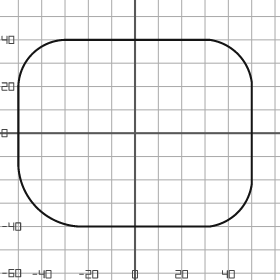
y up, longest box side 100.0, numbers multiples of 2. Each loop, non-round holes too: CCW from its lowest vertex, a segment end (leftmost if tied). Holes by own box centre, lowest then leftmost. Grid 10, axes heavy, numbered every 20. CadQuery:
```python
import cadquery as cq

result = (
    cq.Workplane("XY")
    .moveTo(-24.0, -40.0)
    .lineTo(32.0, -40.0)
    .threePointArc((44.0, -34.0), (50.0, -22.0))
    .lineTo(50.0, 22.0)
    .threePointArc((44.0, 34.0), (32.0, 40.0))
    .lineTo(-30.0, 40.0)
    .threePointArc((-44.0, 34.0), (-50.0, 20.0))
    .lineTo(-50.0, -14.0)
    .threePointArc((-42.0, -32.0), (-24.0, -40.0))
    .close()
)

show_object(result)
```